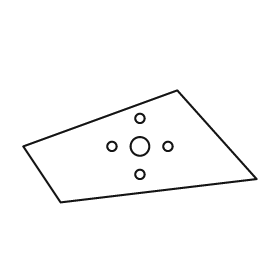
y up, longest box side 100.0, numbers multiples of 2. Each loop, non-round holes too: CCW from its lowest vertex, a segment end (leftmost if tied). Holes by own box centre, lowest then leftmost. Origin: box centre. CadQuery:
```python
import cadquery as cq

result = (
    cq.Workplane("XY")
    .moveTo(-34.0, -24.0)
    .lineTo(50.0, -14.0)
    .lineTo(16.0, 24.0)
    .lineTo(-50.0, 0.0)
    .close()
    .moveTo(0.0, -12.0)
    .circle(2.0)
    .moveTo(-12.0, 0.0)
    .circle(2.0)
    .moveTo(0.0, 0.0)
    .circle(4.0)
    .moveTo(12.0, 0.0)
    .circle(2.0)
    .moveTo(0.0, 12.0)
    .circle(2.0)
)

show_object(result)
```